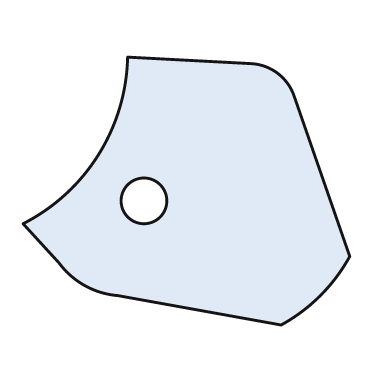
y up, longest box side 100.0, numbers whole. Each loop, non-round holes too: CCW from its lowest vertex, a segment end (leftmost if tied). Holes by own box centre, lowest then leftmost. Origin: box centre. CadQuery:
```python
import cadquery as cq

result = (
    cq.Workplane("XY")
    .moveTo(29.0, -41.0)
    .threePointArc((41.0, -32.0), (50.0, -20.0))
    .lineTo(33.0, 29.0)
    .threePointArc((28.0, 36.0), (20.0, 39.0))
    .lineTo(-18.0, 41.0)
    .threePointArc((-27.0, 11.0), (-50.0, -10.0))
    .lineTo(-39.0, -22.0)
    .threePointArc((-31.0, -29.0), (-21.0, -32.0))
    .close()
    .moveTo(-13.0, -3.0)
    .circle(7.0)
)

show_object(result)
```